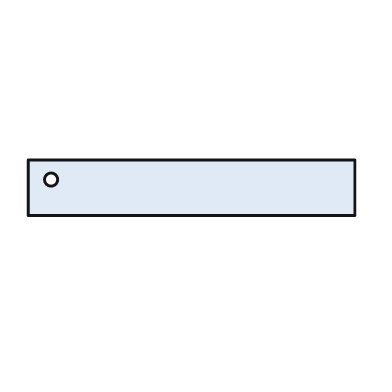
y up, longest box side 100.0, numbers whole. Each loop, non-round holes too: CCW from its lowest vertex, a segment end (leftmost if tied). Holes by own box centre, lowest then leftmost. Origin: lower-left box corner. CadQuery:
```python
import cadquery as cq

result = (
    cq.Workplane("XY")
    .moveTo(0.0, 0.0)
    .lineTo(100.0, 0.0)
    .lineTo(100.0, 17.0)
    .lineTo(0.0, 17.0)
    .close()
    .moveTo(7.0, 11.0)
    .circle(2.0)
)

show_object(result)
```